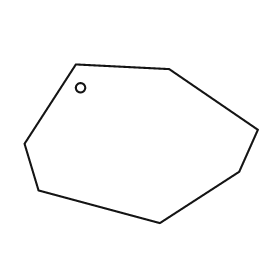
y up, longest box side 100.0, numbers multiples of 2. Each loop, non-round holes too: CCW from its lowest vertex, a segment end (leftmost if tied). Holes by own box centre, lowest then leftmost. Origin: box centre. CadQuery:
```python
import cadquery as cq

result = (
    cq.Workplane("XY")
    .moveTo(8.0, -34.0)
    .lineTo(42.0, -12.0)
    .lineTo(50.0, 6.0)
    .lineTo(12.0, 32.0)
    .lineTo(-28.0, 34.0)
    .lineTo(-50.0, 0.0)
    .lineTo(-44.0, -20.0)
    .close()
    .moveTo(-26.0, 24.0)
    .circle(2.0)
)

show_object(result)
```